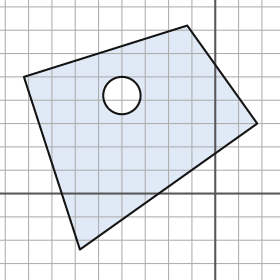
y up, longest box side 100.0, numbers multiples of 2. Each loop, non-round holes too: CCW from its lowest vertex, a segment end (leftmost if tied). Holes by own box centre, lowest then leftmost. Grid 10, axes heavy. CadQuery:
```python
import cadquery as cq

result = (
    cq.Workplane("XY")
    .moveTo(-58.0, -24.0)
    .lineTo(18.0, 30.0)
    .lineTo(-12.0, 72.0)
    .lineTo(-82.0, 50.0)
    .close()
    .moveTo(-40.0, 42.0)
    .circle(8.0)
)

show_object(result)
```